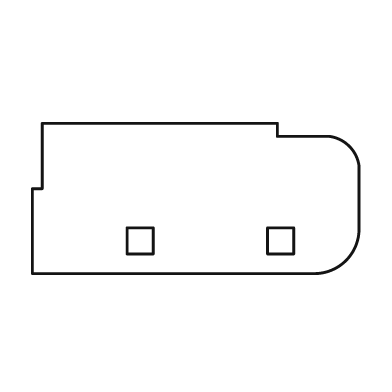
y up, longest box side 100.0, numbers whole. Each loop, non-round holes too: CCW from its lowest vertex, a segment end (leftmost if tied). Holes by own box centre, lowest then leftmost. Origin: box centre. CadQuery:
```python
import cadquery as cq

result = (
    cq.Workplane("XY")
    .moveTo(-50.0, -23.0)
    .lineTo(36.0, -23.0)
    .threePointArc((46.0, -19.0), (50.0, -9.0))
    .lineTo(50.0, 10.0)
    .threePointArc((47.0, 16.0), (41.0, 19.0))
    .lineTo(25.0, 19.0)
    .lineTo(25.0, 23.0)
    .lineTo(-47.0, 23.0)
    .lineTo(-47.0, 3.0)
    .lineTo(-50.0, 3.0)
    .close()
    .moveTo(-21.0, -17.0)
    .lineTo(-13.0, -17.0)
    .lineTo(-13.0, -9.0)
    .lineTo(-21.0, -9.0)
    .close()
    .moveTo(22.0, -17.0)
    .lineTo(30.0, -17.0)
    .lineTo(30.0, -9.0)
    .lineTo(22.0, -9.0)
    .close()
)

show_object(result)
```